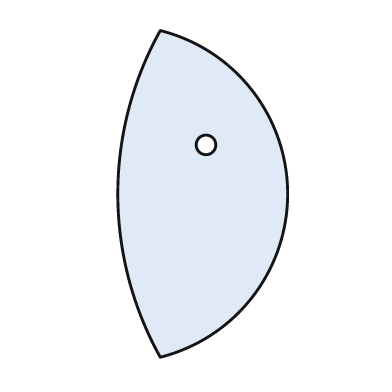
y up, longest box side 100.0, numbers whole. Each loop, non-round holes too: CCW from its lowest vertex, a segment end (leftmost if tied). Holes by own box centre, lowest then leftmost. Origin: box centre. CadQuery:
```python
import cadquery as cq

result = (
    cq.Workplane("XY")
    .moveTo(-13.0, -50.0)
    .threePointArc((26.0, 0.0), (-13.0, 50.0))
    .threePointArc((-26.0, 0.0), (-13.0, -50.0))
    .close()
    .moveTo(1.0, 15.0)
    .circle(3.0)
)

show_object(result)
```